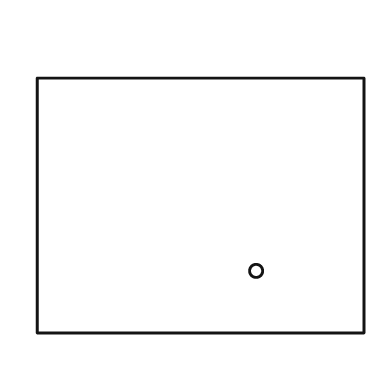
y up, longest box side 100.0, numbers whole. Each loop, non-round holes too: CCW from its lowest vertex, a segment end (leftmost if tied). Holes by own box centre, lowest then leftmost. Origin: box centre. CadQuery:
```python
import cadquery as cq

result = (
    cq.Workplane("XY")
    .moveTo(-50.0, -39.0)
    .lineTo(50.0, -39.0)
    .lineTo(50.0, 39.0)
    .lineTo(-50.0, 39.0)
    .close()
    .moveTo(17.0, -20.0)
    .circle(2.0)
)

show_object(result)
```